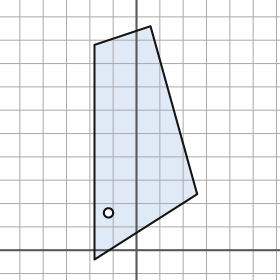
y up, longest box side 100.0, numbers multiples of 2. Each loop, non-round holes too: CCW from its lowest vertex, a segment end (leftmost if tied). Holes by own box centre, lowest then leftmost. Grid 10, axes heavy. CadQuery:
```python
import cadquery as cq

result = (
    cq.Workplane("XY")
    .moveTo(-18.0, -4.0)
    .lineTo(26.0, 24.0)
    .lineTo(6.0, 96.0)
    .lineTo(-18.0, 88.0)
    .close()
    .moveTo(-12.0, 16.0)
    .circle(2.0)
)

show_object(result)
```